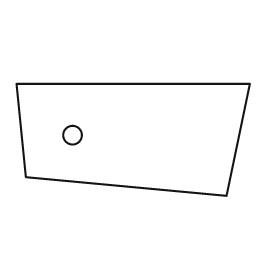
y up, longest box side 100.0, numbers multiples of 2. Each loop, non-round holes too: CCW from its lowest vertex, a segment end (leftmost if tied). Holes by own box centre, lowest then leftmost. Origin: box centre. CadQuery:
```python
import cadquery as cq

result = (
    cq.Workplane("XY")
    .moveTo(40.0, -24.0)
    .lineTo(50.0, 24.0)
    .lineTo(-50.0, 24.0)
    .lineTo(-46.0, -16.0)
    .close()
    .moveTo(-26.0, 2.0)
    .circle(4.0)
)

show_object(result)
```